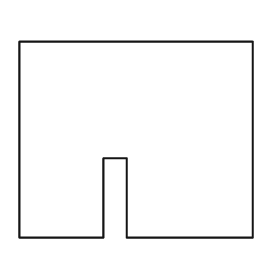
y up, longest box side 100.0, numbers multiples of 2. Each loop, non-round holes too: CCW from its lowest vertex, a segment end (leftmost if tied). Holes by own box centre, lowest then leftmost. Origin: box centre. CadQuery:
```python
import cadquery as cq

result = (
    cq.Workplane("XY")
    .moveTo(-50.0, -42.0)
    .lineTo(-14.0, -42.0)
    .lineTo(-14.0, -8.0)
    .lineTo(-4.0, -8.0)
    .lineTo(-4.0, -42.0)
    .lineTo(50.0, -42.0)
    .lineTo(50.0, 42.0)
    .lineTo(-50.0, 42.0)
    .close()
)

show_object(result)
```